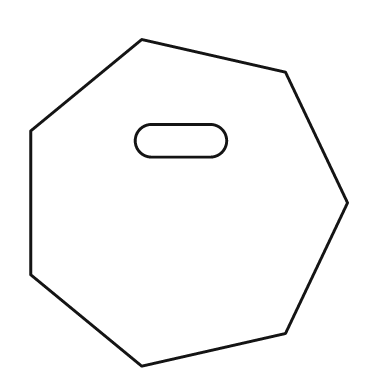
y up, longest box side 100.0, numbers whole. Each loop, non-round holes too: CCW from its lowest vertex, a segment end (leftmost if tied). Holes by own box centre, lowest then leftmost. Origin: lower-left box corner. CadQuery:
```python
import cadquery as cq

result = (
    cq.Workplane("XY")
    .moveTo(34.0, 0.0)
    .lineTo(78.0, 10.0)
    .lineTo(97.0, 50.0)
    .lineTo(78.0, 90.0)
    .lineTo(34.0, 100.0)
    .lineTo(0.0, 72.0)
    .lineTo(0.0, 28.0)
    .close()
    .moveTo(37.0, 64.0)
    .lineTo(55.0, 64.0)
    .threePointArc((60.0, 69.0), (55.0, 74.0))
    .lineTo(37.0, 74.0)
    .threePointArc((32.0, 69.0), (37.0, 64.0))
    .close()
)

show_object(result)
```